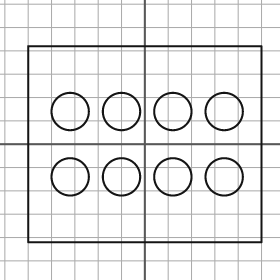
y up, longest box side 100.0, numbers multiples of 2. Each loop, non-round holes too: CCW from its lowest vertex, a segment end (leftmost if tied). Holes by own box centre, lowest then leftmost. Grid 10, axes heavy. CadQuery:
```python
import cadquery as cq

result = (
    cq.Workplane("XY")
    .moveTo(-50.0, -42.0)
    .lineTo(50.0, -42.0)
    .lineTo(50.0, 42.0)
    .lineTo(-50.0, 42.0)
    .close()
    .moveTo(-32.0, -14.0)
    .circle(8.0)
    .moveTo(-10.0, -14.0)
    .circle(8.0)
    .moveTo(12.0, -14.0)
    .circle(8.0)
    .moveTo(34.0, -14.0)
    .circle(8.0)
    .moveTo(-32.0, 14.0)
    .circle(8.0)
    .moveTo(-10.0, 14.0)
    .circle(8.0)
    .moveTo(12.0, 14.0)
    .circle(8.0)
    .moveTo(34.0, 14.0)
    .circle(8.0)
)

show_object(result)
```